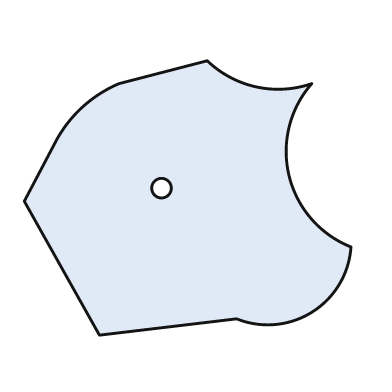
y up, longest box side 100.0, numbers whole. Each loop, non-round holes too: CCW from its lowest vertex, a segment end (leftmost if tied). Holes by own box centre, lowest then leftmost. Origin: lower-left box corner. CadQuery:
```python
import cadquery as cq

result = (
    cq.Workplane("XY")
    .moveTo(23.0, 0.0)
    .lineTo(65.0, 5.0)
    .threePointArc((88.0, 7.0), (100.0, 27.0))
    .threePointArc((81.0, 49.0), (88.0, 77.0))
    .threePointArc((71.0, 76.0), (56.0, 84.0))
    .lineTo(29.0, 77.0)
    .threePointArc((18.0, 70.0), (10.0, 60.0))
    .lineTo(0.0, 41.0)
    .close()
    .moveTo(42.0, 45.0)
    .circle(3.0)
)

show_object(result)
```